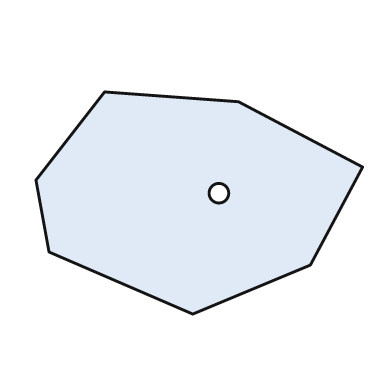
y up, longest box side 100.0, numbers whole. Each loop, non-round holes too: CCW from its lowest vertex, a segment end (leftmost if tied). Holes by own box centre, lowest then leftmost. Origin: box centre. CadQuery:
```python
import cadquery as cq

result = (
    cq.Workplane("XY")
    .moveTo(-2.0, -34.0)
    .lineTo(34.0, -19.0)
    .lineTo(50.0, 11.0)
    .lineTo(12.0, 31.0)
    .lineTo(-29.0, 34.0)
    .lineTo(-50.0, 7.0)
    .lineTo(-46.0, -15.0)
    .close()
    .moveTo(6.0, 3.0)
    .circle(3.0)
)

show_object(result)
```